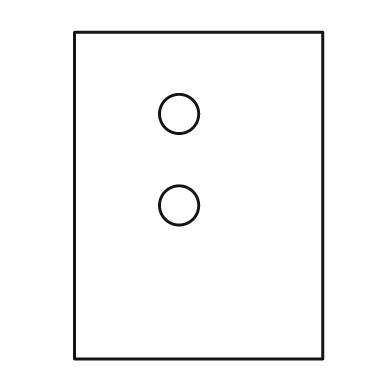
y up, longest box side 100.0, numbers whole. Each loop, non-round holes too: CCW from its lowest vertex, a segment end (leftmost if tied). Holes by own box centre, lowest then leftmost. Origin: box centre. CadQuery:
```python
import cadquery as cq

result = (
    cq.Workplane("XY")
    .moveTo(-38.0, -50.0)
    .lineTo(38.0, -50.0)
    .lineTo(38.0, 50.0)
    .lineTo(-38.0, 50.0)
    .close()
    .moveTo(-6.0, -3.0)
    .circle(6.0)
    .moveTo(-6.0, 25.0)
    .circle(6.0)
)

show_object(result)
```